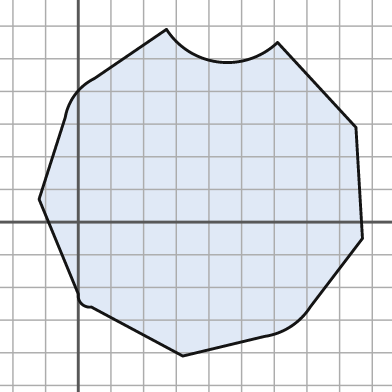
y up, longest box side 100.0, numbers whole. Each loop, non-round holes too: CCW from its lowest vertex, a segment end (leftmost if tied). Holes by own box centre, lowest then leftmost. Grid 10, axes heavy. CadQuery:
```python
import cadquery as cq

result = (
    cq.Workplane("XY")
    .moveTo(32.0, -41.0)
    .lineTo(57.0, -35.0)
    .threePointArc((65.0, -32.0), (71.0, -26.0))
    .lineTo(87.0, -5.0)
    .lineTo(85.0, 29.0)
    .lineTo(61.0, 55.0)
    .threePointArc((43.0, 49.0), (27.0, 59.0))
    .lineTo(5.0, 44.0)
    .threePointArc((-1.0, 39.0), (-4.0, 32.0))
    .lineTo(-12.0, 7.0)
    .lineTo(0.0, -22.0)
    .threePointArc((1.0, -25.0), (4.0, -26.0))
    .close()
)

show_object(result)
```